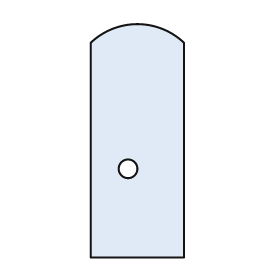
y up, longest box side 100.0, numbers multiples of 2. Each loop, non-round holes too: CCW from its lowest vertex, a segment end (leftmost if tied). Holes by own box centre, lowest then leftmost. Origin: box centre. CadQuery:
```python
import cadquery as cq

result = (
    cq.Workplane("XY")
    .moveTo(-20.0, -50.0)
    .lineTo(20.0, -50.0)
    .lineTo(20.0, 42.0)
    .threePointArc((0.0, 50.0), (-20.0, 42.0))
    .close()
    .moveTo(-4.0, -12.0)
    .circle(4.0)
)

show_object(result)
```